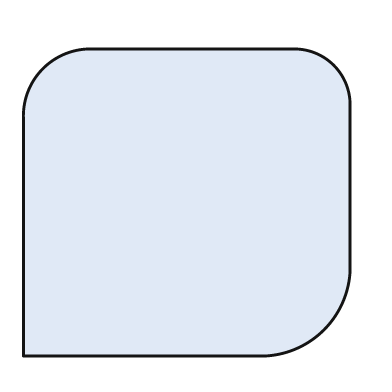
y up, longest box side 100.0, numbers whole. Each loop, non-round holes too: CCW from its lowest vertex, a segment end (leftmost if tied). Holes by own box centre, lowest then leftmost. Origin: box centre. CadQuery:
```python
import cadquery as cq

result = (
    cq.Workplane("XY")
    .moveTo(-50.0, -47.0)
    .lineTo(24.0, -47.0)
    .threePointArc((42.0, -39.0), (50.0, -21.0))
    .lineTo(50.0, 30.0)
    .threePointArc((45.0, 42.0), (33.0, 47.0))
    .lineTo(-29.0, 47.0)
    .threePointArc((-44.0, 41.0), (-50.0, 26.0))
    .close()
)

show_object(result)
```